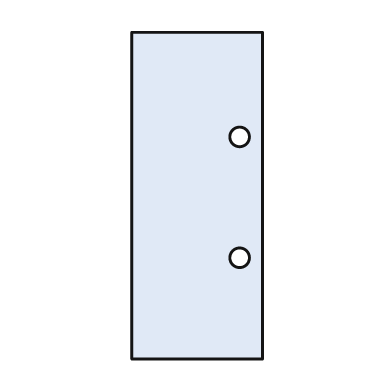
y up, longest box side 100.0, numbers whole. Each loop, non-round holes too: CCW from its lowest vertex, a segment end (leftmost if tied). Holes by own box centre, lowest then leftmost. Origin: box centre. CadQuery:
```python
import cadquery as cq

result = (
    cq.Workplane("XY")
    .moveTo(-20.0, -50.0)
    .lineTo(20.0, -50.0)
    .lineTo(20.0, 50.0)
    .lineTo(-20.0, 50.0)
    .close()
    .moveTo(13.0, -19.0)
    .circle(3.0)
    .moveTo(13.0, 18.0)
    .circle(3.0)
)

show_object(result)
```